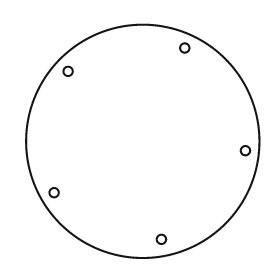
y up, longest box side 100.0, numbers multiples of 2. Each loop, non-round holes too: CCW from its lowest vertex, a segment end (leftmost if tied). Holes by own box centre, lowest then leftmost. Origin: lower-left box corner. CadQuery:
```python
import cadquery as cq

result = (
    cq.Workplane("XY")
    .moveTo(50.0, 50.0)
    .circle(50.0)
    .moveTo(58.0, 8.0)
    .circle(2.0)
    .moveTo(12.0, 28.0)
    .circle(2.0)
    .moveTo(94.0, 46.0)
    .circle(2.0)
    .moveTo(18.0, 80.0)
    .circle(2.0)
    .moveTo(68.0, 90.0)
    .circle(2.0)
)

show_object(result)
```